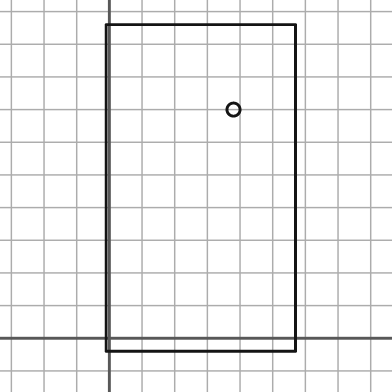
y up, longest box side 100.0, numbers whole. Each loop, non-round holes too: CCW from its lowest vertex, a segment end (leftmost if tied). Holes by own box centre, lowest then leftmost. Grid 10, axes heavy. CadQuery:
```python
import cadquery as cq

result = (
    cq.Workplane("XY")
    .moveTo(-1.0, -4.0)
    .lineTo(57.0, -4.0)
    .lineTo(57.0, 96.0)
    .lineTo(-1.0, 96.0)
    .close()
    .moveTo(38.0, 70.0)
    .circle(2.0)
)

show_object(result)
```